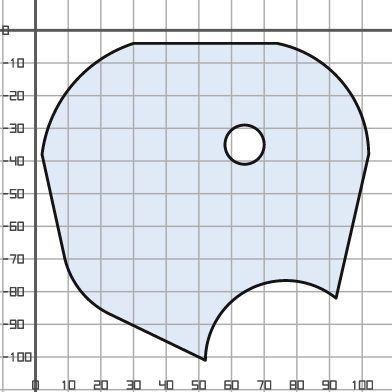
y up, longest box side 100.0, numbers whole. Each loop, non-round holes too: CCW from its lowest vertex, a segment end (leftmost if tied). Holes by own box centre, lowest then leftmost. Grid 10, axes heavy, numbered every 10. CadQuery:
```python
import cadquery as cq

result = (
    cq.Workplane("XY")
    .moveTo(52.0, -101.0)
    .threePointArc((66.0, -79.0), (92.0, -82.0))
    .lineTo(102.0, -38.0)
    .threePointArc((94.0, -16.0), (74.0, -4.0))
    .lineTo(30.0, -4.0)
    .threePointArc((11.0, -17.0), (2.0, -38.0))
    .lineTo(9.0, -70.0)
    .threePointArc((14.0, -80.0), (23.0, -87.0))
    .close()
    .moveTo(64.0, -35.0)
    .circle(6.0)
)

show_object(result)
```